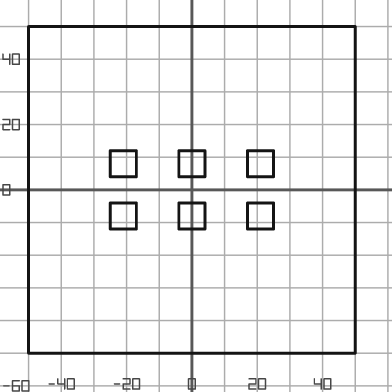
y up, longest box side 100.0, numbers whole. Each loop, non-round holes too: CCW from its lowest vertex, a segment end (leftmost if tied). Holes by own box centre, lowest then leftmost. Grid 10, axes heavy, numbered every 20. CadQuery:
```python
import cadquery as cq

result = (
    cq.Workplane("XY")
    .moveTo(-50.0, -50.0)
    .lineTo(50.0, -50.0)
    .lineTo(50.0, 50.0)
    .lineTo(-50.0, 50.0)
    .close()
    .moveTo(-25.0, -12.0)
    .lineTo(-17.0, -12.0)
    .lineTo(-17.0, -4.0)
    .lineTo(-25.0, -4.0)
    .close()
    .moveTo(-4.0, -12.0)
    .lineTo(4.0, -12.0)
    .lineTo(4.0, -4.0)
    .lineTo(-4.0, -4.0)
    .close()
    .moveTo(17.0, -12.0)
    .lineTo(25.0, -12.0)
    .lineTo(25.0, -4.0)
    .lineTo(17.0, -4.0)
    .close()
    .moveTo(-25.0, 4.0)
    .lineTo(-17.0, 4.0)
    .lineTo(-17.0, 12.0)
    .lineTo(-25.0, 12.0)
    .close()
    .moveTo(-4.0, 4.0)
    .lineTo(4.0, 4.0)
    .lineTo(4.0, 12.0)
    .lineTo(-4.0, 12.0)
    .close()
    .moveTo(17.0, 4.0)
    .lineTo(25.0, 4.0)
    .lineTo(25.0, 12.0)
    .lineTo(17.0, 12.0)
    .close()
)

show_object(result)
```